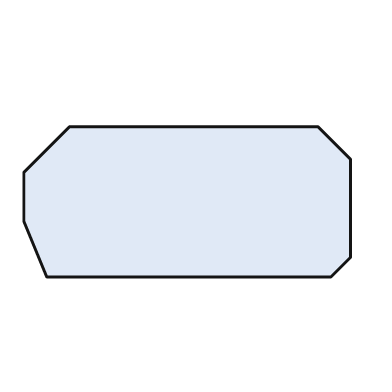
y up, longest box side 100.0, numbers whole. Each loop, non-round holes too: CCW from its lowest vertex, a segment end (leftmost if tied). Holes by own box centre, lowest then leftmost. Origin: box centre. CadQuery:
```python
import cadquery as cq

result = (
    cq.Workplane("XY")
    .moveTo(-43.0, -23.0)
    .lineTo(44.0, -23.0)
    .lineTo(50.0, -17.0)
    .lineTo(50.0, 13.0)
    .lineTo(40.0, 23.0)
    .lineTo(-36.0, 23.0)
    .lineTo(-50.0, 9.0)
    .lineTo(-50.0, -6.0)
    .close()
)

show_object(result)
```